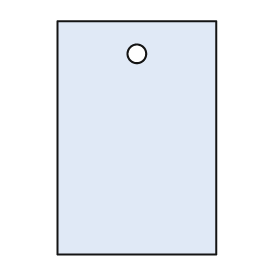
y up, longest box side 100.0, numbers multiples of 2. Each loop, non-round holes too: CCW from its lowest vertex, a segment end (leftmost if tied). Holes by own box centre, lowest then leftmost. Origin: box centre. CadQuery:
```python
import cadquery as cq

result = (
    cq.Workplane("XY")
    .moveTo(-34.0, -50.0)
    .lineTo(34.0, -50.0)
    .lineTo(34.0, 50.0)
    .lineTo(-34.0, 50.0)
    .close()
    .moveTo(0.0, 36.0)
    .circle(4.0)
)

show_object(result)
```